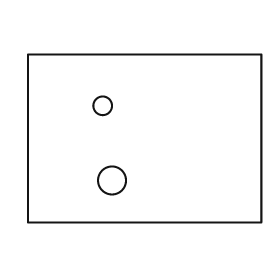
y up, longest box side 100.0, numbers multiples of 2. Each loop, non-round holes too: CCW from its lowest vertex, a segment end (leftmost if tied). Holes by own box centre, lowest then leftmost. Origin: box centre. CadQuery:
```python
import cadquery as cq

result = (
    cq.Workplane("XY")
    .moveTo(-50.0, -36.0)
    .lineTo(50.0, -36.0)
    .lineTo(50.0, 36.0)
    .lineTo(-50.0, 36.0)
    .close()
    .moveTo(-14.0, -18.0)
    .circle(6.0)
    .moveTo(-18.0, 14.0)
    .circle(4.0)
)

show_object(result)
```